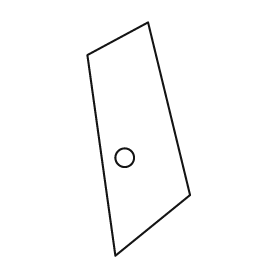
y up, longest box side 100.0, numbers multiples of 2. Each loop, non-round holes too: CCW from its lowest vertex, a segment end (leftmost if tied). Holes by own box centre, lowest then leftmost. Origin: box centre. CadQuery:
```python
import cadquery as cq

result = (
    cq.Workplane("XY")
    .moveTo(-10.0, -50.0)
    .lineTo(22.0, -24.0)
    .lineTo(4.0, 50.0)
    .lineTo(-22.0, 36.0)
    .close()
    .moveTo(-6.0, -8.0)
    .circle(4.0)
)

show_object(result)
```